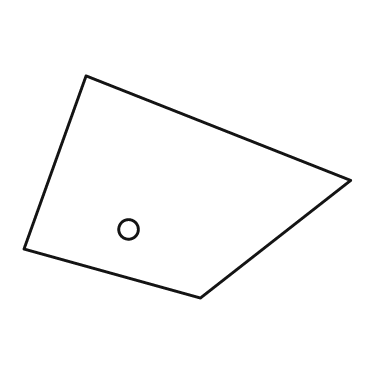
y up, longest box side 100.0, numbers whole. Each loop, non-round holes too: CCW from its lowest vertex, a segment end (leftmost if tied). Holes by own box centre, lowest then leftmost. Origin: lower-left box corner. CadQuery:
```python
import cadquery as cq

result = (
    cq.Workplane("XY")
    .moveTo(54.0, 0.0)
    .lineTo(100.0, 36.0)
    .lineTo(19.0, 68.0)
    .lineTo(0.0, 15.0)
    .close()
    .moveTo(32.0, 21.0)
    .circle(3.0)
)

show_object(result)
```